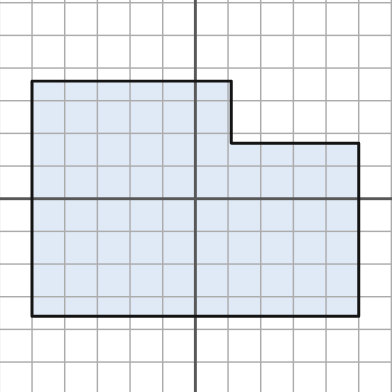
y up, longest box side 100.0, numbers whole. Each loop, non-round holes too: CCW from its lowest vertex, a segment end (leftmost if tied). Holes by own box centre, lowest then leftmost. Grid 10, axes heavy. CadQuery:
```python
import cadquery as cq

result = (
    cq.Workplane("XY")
    .moveTo(-50.0, -36.0)
    .lineTo(50.0, -36.0)
    .lineTo(50.0, 17.0)
    .lineTo(11.0, 17.0)
    .lineTo(11.0, 36.0)
    .lineTo(-50.0, 36.0)
    .close()
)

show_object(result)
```